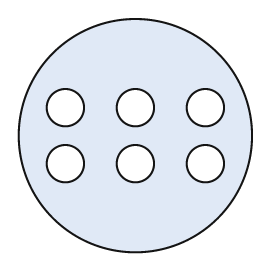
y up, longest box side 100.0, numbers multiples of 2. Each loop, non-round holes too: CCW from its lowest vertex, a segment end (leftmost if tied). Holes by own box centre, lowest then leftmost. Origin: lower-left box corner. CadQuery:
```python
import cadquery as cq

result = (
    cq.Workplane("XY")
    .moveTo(50.0, 50.0)
    .circle(50.0)
    .moveTo(20.0, 38.0)
    .circle(8.0)
    .moveTo(50.0, 38.0)
    .circle(8.0)
    .moveTo(80.0, 38.0)
    .circle(8.0)
    .moveTo(20.0, 62.0)
    .circle(8.0)
    .moveTo(50.0, 62.0)
    .circle(8.0)
    .moveTo(80.0, 62.0)
    .circle(8.0)
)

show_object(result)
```